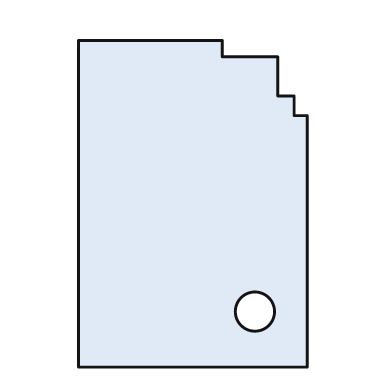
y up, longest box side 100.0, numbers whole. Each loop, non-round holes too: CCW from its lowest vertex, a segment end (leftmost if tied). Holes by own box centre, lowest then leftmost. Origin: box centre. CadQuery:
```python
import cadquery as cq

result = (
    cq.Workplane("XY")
    .moveTo(-35.0, -50.0)
    .lineTo(35.0, -50.0)
    .lineTo(35.0, 27.0)
    .lineTo(31.0, 27.0)
    .lineTo(31.0, 33.0)
    .lineTo(26.0, 33.0)
    .lineTo(26.0, 45.0)
    .lineTo(9.0, 45.0)
    .lineTo(9.0, 50.0)
    .lineTo(-35.0, 50.0)
    .close()
    .moveTo(19.0, -33.0)
    .circle(6.0)
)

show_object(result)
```